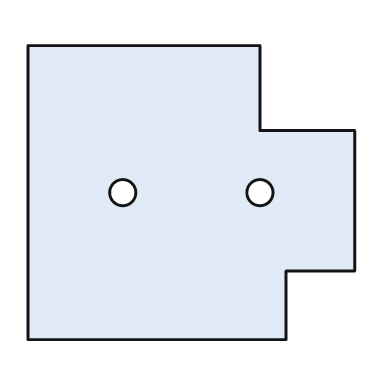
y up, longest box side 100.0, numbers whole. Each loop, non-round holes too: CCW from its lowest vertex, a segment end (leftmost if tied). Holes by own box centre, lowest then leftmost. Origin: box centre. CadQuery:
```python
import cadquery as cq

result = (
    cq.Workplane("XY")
    .moveTo(-50.0, -45.0)
    .lineTo(29.0, -45.0)
    .lineTo(29.0, -24.0)
    .lineTo(50.0, -24.0)
    .lineTo(50.0, 19.0)
    .lineTo(21.0, 19.0)
    .lineTo(21.0, 45.0)
    .lineTo(-50.0, 45.0)
    .close()
    .moveTo(-21.0, 0.0)
    .circle(4.0)
    .moveTo(21.0, 0.0)
    .circle(4.0)
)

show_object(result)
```